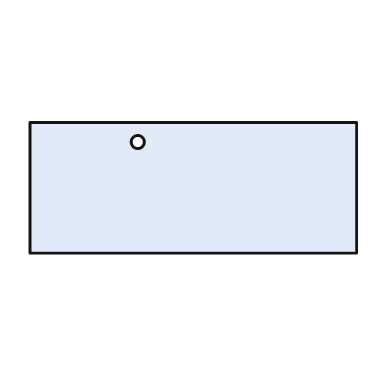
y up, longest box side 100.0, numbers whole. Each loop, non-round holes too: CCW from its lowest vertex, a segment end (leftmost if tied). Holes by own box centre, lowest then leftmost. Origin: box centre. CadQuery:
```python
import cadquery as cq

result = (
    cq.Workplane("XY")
    .moveTo(-50.0, -20.0)
    .lineTo(50.0, -20.0)
    .lineTo(50.0, 20.0)
    .lineTo(-50.0, 20.0)
    .close()
    .moveTo(-17.0, 14.0)
    .circle(2.0)
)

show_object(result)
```